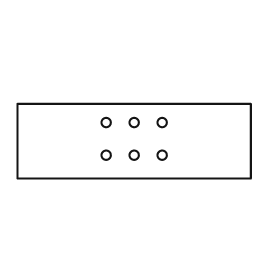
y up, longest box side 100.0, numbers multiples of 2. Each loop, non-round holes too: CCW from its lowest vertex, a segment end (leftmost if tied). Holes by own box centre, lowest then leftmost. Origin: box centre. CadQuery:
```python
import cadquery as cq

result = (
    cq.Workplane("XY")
    .moveTo(-50.0, -16.0)
    .lineTo(50.0, -16.0)
    .lineTo(50.0, 16.0)
    .lineTo(-50.0, 16.0)
    .close()
    .moveTo(-12.0, -6.0)
    .circle(2.0)
    .moveTo(0.0, -6.0)
    .circle(2.0)
    .moveTo(12.0, -6.0)
    .circle(2.0)
    .moveTo(-12.0, 8.0)
    .circle(2.0)
    .moveTo(0.0, 8.0)
    .circle(2.0)
    .moveTo(12.0, 8.0)
    .circle(2.0)
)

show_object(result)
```